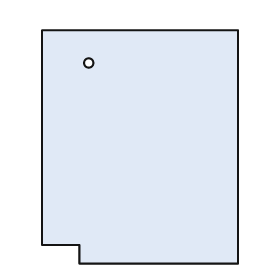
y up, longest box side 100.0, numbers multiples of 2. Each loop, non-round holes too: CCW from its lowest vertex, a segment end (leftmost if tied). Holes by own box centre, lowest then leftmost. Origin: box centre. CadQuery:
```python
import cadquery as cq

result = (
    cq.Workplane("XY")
    .moveTo(-26.0, -50.0)
    .lineTo(42.0, -50.0)
    .lineTo(42.0, 50.0)
    .lineTo(-42.0, 50.0)
    .lineTo(-42.0, -42.0)
    .lineTo(-26.0, -42.0)
    .close()
    .moveTo(-22.0, 36.0)
    .circle(2.0)
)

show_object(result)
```